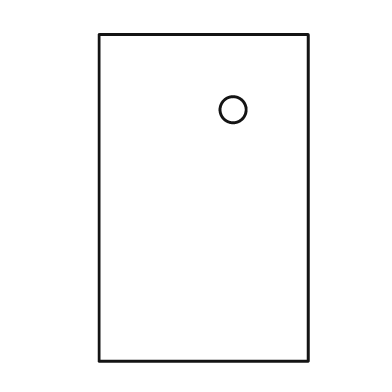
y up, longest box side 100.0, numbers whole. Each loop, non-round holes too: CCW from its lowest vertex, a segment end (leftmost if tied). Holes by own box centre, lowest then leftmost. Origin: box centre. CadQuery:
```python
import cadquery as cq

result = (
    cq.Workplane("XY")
    .moveTo(-32.0, -50.0)
    .lineTo(32.0, -50.0)
    .lineTo(32.0, 50.0)
    .lineTo(-32.0, 50.0)
    .close()
    .moveTo(9.0, 27.0)
    .circle(4.0)
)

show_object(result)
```